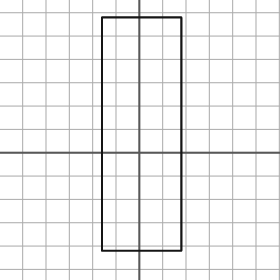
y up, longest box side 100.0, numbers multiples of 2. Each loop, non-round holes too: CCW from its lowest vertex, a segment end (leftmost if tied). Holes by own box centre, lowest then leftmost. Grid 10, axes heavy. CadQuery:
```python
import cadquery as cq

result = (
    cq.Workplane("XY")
    .moveTo(-16.0, -42.0)
    .lineTo(18.0, -42.0)
    .lineTo(18.0, 58.0)
    .lineTo(-16.0, 58.0)
    .close()
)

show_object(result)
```